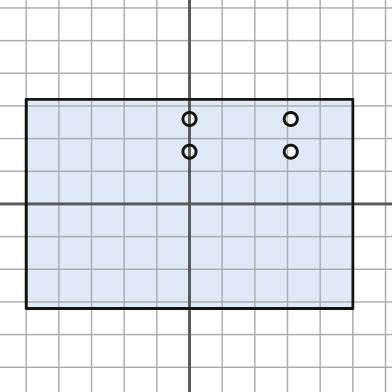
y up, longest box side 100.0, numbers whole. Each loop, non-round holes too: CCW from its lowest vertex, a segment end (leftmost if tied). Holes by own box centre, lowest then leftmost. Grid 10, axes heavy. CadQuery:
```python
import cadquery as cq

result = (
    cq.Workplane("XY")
    .moveTo(-50.0, -32.0)
    .lineTo(50.0, -32.0)
    .lineTo(50.0, 32.0)
    .lineTo(-50.0, 32.0)
    .close()
    .moveTo(0.0, 16.0)
    .circle(2.0)
    .moveTo(31.0, 16.0)
    .circle(2.0)
    .moveTo(0.0, 26.0)
    .circle(2.0)
    .moveTo(31.0, 26.0)
    .circle(2.0)
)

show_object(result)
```